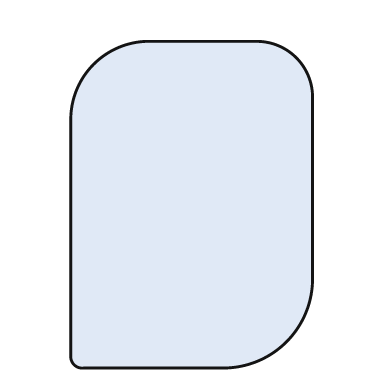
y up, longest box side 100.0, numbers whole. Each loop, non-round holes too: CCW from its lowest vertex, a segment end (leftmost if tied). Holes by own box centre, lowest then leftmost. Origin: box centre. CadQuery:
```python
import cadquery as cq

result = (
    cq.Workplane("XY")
    .moveTo(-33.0, -50.0)
    .lineTo(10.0, -50.0)
    .threePointArc((29.0, -42.0), (37.0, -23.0))
    .lineTo(37.0, 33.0)
    .threePointArc((32.0, 45.0), (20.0, 50.0))
    .lineTo(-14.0, 50.0)
    .threePointArc((-30.0, 43.0), (-37.0, 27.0))
    .lineTo(-37.0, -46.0)
    .threePointArc((-36.0, -49.0), (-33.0, -50.0))
    .close()
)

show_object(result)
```